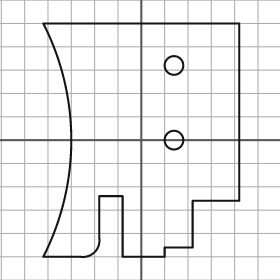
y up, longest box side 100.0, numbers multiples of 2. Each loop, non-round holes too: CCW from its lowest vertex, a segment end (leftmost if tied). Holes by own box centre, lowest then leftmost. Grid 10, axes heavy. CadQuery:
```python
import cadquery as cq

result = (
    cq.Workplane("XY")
    .moveTo(-42.0, -50.0)
    .lineTo(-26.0, -50.0)
    .threePointArc((-20.0, -48.0), (-18.0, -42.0))
    .lineTo(-18.0, -24.0)
    .lineTo(-8.0, -24.0)
    .lineTo(-8.0, -50.0)
    .lineTo(10.0, -50.0)
    .lineTo(10.0, -46.0)
    .lineTo(22.0, -46.0)
    .lineTo(22.0, -26.0)
    .lineTo(42.0, -26.0)
    .lineTo(42.0, 50.0)
    .lineTo(-42.0, 50.0)
    .threePointArc((-30.0, 0.0), (-42.0, -50.0))
    .close()
    .moveTo(14.0, 0.0)
    .circle(4.0)
    .moveTo(14.0, 32.0)
    .circle(4.0)
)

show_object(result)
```